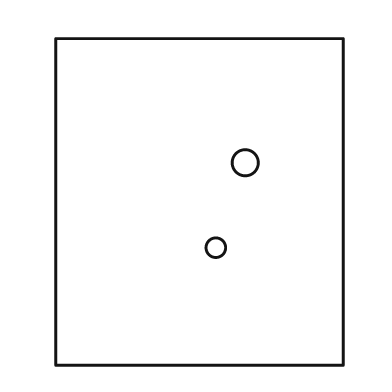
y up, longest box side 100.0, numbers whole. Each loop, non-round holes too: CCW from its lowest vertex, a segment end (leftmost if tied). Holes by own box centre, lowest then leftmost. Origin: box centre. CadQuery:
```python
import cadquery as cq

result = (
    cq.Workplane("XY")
    .moveTo(-44.0, -50.0)
    .lineTo(44.0, -50.0)
    .lineTo(44.0, 50.0)
    .lineTo(-44.0, 50.0)
    .close()
    .moveTo(5.0, -14.0)
    .circle(3.0)
    .moveTo(14.0, 12.0)
    .circle(4.0)
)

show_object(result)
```